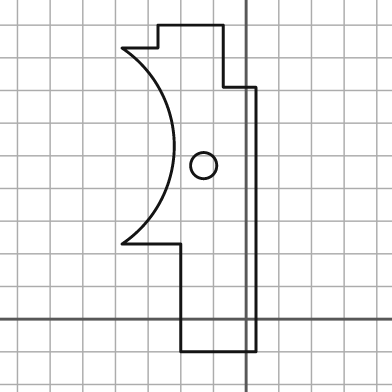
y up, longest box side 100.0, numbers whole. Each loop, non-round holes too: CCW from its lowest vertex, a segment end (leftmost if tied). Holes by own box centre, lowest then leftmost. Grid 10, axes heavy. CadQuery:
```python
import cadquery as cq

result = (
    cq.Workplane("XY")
    .moveTo(-20.0, -10.0)
    .lineTo(3.0, -10.0)
    .lineTo(3.0, 71.0)
    .lineTo(-7.0, 71.0)
    .lineTo(-7.0, 90.0)
    .lineTo(-27.0, 90.0)
    .lineTo(-27.0, 83.0)
    .lineTo(-38.0, 83.0)
    .threePointArc((-22.0, 53.0), (-38.0, 23.0))
    .lineTo(-20.0, 23.0)
    .close()
    .moveTo(-13.0, 47.0)
    .circle(4.0)
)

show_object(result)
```